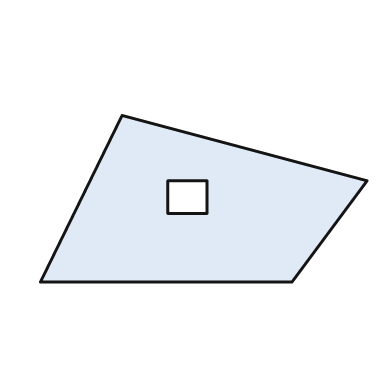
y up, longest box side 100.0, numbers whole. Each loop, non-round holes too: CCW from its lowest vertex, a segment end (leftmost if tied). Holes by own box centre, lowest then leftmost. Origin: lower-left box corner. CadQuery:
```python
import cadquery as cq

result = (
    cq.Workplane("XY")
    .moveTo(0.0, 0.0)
    .lineTo(77.0, 0.0)
    .lineTo(100.0, 31.0)
    .lineTo(25.0, 51.0)
    .close()
    .moveTo(39.0, 21.0)
    .lineTo(51.0, 21.0)
    .lineTo(51.0, 31.0)
    .lineTo(39.0, 31.0)
    .close()
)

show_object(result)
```